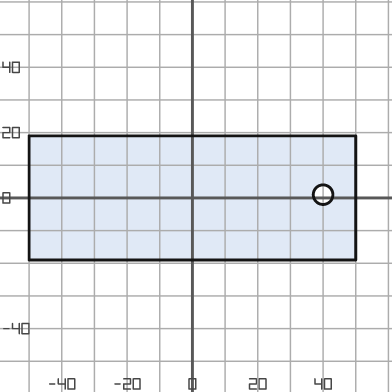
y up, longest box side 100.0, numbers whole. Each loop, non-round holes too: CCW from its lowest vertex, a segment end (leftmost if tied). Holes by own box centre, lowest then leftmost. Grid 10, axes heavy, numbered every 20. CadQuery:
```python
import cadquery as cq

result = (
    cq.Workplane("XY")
    .moveTo(-50.0, -19.0)
    .lineTo(50.0, -19.0)
    .lineTo(50.0, 19.0)
    .lineTo(-50.0, 19.0)
    .close()
    .moveTo(40.0, 1.0)
    .circle(3.0)
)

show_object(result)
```